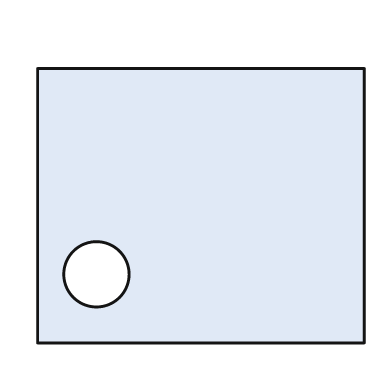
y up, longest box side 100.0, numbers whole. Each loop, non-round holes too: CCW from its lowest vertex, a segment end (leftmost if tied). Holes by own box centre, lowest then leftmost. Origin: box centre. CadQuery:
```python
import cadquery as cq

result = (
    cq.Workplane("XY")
    .moveTo(-50.0, -42.0)
    .lineTo(50.0, -42.0)
    .lineTo(50.0, 42.0)
    .lineTo(-50.0, 42.0)
    .close()
    .moveTo(-32.0, -21.0)
    .circle(10.0)
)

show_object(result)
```